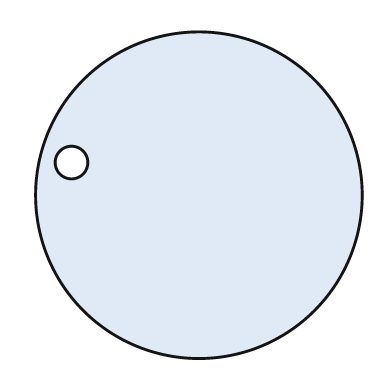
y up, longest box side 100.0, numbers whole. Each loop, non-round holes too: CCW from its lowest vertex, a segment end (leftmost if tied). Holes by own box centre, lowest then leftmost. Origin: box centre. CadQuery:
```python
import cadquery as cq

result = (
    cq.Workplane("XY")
    .moveTo(0.0, 0.0)
    .circle(50.0)
    .moveTo(-39.0, 10.0)
    .circle(5.0)
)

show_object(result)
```